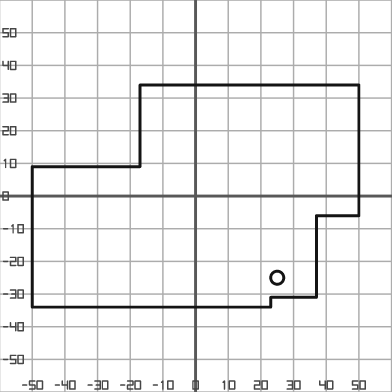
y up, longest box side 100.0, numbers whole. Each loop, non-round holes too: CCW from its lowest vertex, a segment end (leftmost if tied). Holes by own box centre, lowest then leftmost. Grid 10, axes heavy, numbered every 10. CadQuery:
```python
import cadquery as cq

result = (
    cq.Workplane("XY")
    .moveTo(-50.0, -34.0)
    .lineTo(23.0, -34.0)
    .lineTo(23.0, -31.0)
    .lineTo(37.0, -31.0)
    .lineTo(37.0, -6.0)
    .lineTo(50.0, -6.0)
    .lineTo(50.0, 34.0)
    .lineTo(-17.0, 34.0)
    .lineTo(-17.0, 9.0)
    .lineTo(-50.0, 9.0)
    .close()
    .moveTo(25.0, -25.0)
    .circle(2.0)
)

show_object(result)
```